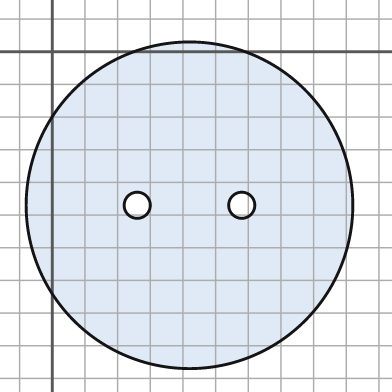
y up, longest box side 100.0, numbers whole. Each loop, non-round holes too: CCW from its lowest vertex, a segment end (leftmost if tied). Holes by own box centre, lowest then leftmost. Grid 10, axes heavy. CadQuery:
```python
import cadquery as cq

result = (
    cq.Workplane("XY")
    .moveTo(42.0, -47.0)
    .circle(50.0)
    .moveTo(26.0, -47.0)
    .circle(4.0)
    .moveTo(58.0, -47.0)
    .circle(4.0)
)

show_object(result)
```